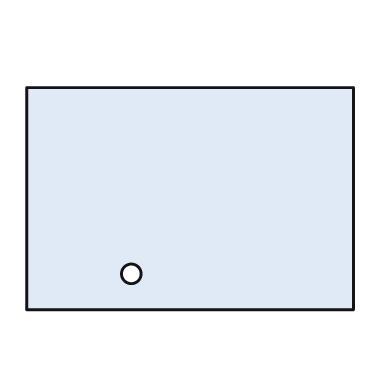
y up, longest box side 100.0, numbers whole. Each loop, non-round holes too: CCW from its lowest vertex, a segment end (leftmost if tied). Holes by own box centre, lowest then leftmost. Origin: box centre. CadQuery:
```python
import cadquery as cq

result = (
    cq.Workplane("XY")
    .moveTo(-50.0, -34.0)
    .lineTo(50.0, -34.0)
    .lineTo(50.0, 34.0)
    .lineTo(-50.0, 34.0)
    .close()
    .moveTo(-18.0, -23.0)
    .circle(3.0)
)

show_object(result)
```